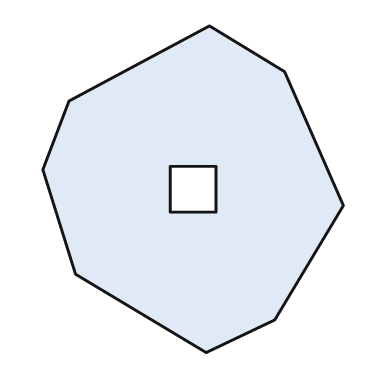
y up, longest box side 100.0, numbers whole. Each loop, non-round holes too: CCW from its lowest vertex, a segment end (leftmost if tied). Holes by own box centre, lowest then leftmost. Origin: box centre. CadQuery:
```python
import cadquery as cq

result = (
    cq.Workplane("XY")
    .moveTo(4.0, -50.0)
    .lineTo(25.0, -40.0)
    .lineTo(46.0, -5.0)
    .lineTo(28.0, 36.0)
    .lineTo(5.0, 50.0)
    .lineTo(-38.0, 27.0)
    .lineTo(-46.0, 6.0)
    .lineTo(-36.0, -26.0)
    .close()
    .moveTo(-7.0, -7.0)
    .lineTo(7.0, -7.0)
    .lineTo(7.0, 7.0)
    .lineTo(-7.0, 7.0)
    .close()
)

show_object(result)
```